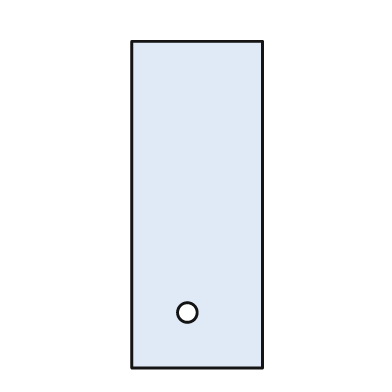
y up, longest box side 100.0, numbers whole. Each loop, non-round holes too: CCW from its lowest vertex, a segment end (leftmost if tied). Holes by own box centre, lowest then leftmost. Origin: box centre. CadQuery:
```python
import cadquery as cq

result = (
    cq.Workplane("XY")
    .moveTo(-20.0, -50.0)
    .lineTo(20.0, -50.0)
    .lineTo(20.0, 50.0)
    .lineTo(-20.0, 50.0)
    .close()
    .moveTo(-3.0, -33.0)
    .circle(3.0)
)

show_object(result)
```